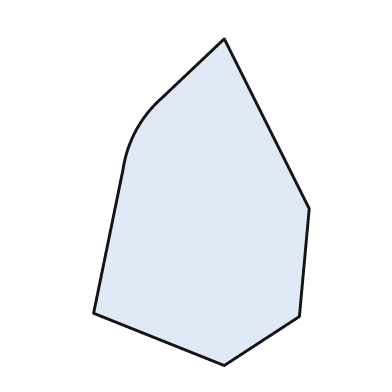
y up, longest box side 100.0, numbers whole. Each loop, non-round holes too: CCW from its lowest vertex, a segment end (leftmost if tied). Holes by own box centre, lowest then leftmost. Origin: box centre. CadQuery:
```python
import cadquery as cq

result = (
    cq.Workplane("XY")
    .moveTo(7.0, -50.0)
    .lineTo(30.0, -35.0)
    .lineTo(33.0, -2.0)
    .lineTo(7.0, 50.0)
    .lineTo(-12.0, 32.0)
    .threePointArc((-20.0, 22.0), (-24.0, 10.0))
    .lineTo(-33.0, -34.0)
    .close()
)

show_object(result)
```